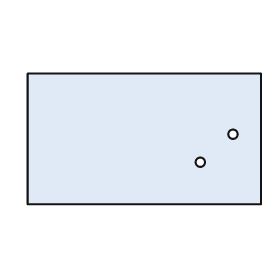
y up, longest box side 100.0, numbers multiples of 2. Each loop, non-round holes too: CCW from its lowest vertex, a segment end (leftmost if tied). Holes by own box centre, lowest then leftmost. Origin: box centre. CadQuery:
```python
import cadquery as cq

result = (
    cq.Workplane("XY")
    .moveTo(-50.0, -28.0)
    .lineTo(50.0, -28.0)
    .lineTo(50.0, 28.0)
    .lineTo(-50.0, 28.0)
    .close()
    .moveTo(24.0, -10.0)
    .circle(2.0)
    .moveTo(38.0, 2.0)
    .circle(2.0)
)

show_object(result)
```